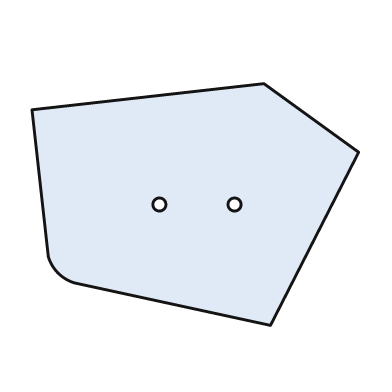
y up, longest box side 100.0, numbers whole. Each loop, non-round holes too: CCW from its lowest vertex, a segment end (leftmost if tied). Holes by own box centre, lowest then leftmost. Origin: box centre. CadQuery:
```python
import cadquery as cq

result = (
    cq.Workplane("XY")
    .moveTo(23.0, -37.0)
    .lineTo(50.0, 16.0)
    .lineTo(21.0, 37.0)
    .lineTo(-50.0, 29.0)
    .lineTo(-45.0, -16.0)
    .threePointArc((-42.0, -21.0), (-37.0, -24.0))
    .close()
    .moveTo(-11.0, 0.0)
    .circle(2.0)
    .moveTo(12.0, 0.0)
    .circle(2.0)
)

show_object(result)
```